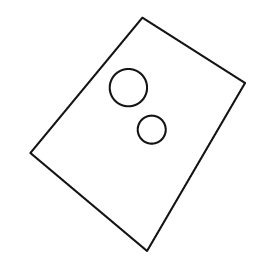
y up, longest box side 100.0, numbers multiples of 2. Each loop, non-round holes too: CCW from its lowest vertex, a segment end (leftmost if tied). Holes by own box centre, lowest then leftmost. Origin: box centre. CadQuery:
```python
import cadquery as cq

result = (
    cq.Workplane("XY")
    .moveTo(4.0, -50.0)
    .lineTo(46.0, 22.0)
    .lineTo(2.0, 50.0)
    .lineTo(-46.0, -8.0)
    .close()
    .moveTo(6.0, 2.0)
    .circle(6.0)
    .moveTo(-4.0, 20.0)
    .circle(8.0)
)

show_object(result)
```